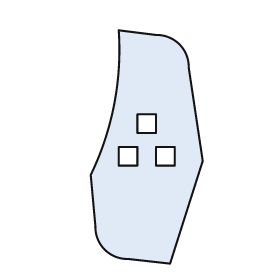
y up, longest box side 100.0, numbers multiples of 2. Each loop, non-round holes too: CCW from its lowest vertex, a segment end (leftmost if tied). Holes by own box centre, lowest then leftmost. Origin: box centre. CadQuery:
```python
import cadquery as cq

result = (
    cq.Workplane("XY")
    .moveTo(10.0, -50.0)
    .lineTo(24.0, -6.0)
    .lineTo(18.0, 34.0)
    .threePointArc((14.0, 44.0), (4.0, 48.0))
    .lineTo(-12.0, 50.0)
    .threePointArc((-14.0, 18.0), (-24.0, -12.0))
    .lineTo(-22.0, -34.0)
    .threePointArc((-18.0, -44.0), (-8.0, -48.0))
    .close()
    .moveTo(-12.0, -8.0)
    .lineTo(-4.0, -8.0)
    .lineTo(-4.0, 0.0)
    .lineTo(-12.0, 0.0)
    .close()
    .moveTo(4.0, -8.0)
    .lineTo(12.0, -8.0)
    .lineTo(12.0, 0.0)
    .lineTo(4.0, 0.0)
    .close()
    .moveTo(-4.0, 6.0)
    .lineTo(4.0, 6.0)
    .lineTo(4.0, 14.0)
    .lineTo(-4.0, 14.0)
    .close()
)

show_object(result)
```